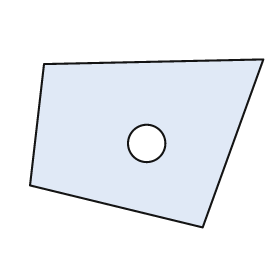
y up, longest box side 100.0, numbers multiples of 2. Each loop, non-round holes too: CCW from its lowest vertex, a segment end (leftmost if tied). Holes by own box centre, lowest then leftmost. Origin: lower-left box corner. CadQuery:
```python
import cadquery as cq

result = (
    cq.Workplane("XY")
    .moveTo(74.0, 0.0)
    .lineTo(100.0, 72.0)
    .lineTo(6.0, 70.0)
    .lineTo(0.0, 18.0)
    .close()
    .moveTo(50.0, 36.0)
    .circle(8.0)
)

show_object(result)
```